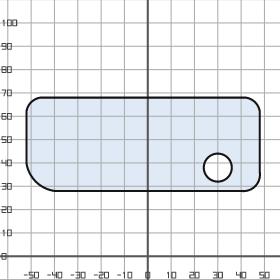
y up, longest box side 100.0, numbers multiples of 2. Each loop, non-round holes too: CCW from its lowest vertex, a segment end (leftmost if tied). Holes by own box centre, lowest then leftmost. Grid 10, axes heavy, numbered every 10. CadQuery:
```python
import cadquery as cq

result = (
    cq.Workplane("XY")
    .moveTo(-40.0, 28.0)
    .lineTo(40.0, 28.0)
    .threePointArc((46.0, 30.0), (48.0, 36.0))
    .lineTo(48.0, 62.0)
    .threePointArc((46.0, 66.0), (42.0, 68.0))
    .lineTo(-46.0, 68.0)
    .threePointArc((-50.0, 66.0), (-52.0, 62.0))
    .lineTo(-52.0, 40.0)
    .threePointArc((-48.0, 32.0), (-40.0, 28.0))
    .close()
    .moveTo(30.0, 38.0)
    .circle(6.0)
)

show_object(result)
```